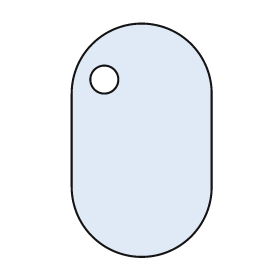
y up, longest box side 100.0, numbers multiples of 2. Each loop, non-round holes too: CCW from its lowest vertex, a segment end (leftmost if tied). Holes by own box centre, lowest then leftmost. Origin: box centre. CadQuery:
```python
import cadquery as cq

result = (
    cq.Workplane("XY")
    .moveTo(-30.0, -20.0)
    .threePointArc((0.0, -50.0), (30.0, -20.0))
    .lineTo(30.0, 20.0)
    .threePointArc((0.0, 50.0), (-30.0, 20.0))
    .close()
    .moveTo(-16.0, 26.0)
    .circle(6.0)
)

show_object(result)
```